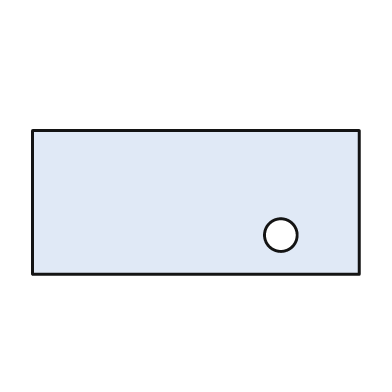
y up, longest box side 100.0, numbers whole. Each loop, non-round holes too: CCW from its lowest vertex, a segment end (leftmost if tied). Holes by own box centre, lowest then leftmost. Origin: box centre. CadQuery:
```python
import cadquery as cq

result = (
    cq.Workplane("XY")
    .moveTo(-50.0, -22.0)
    .lineTo(50.0, -22.0)
    .lineTo(50.0, 22.0)
    .lineTo(-50.0, 22.0)
    .close()
    .moveTo(26.0, -10.0)
    .circle(5.0)
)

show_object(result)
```